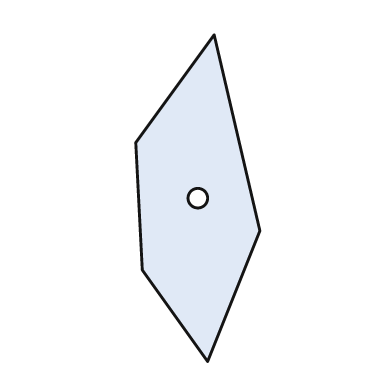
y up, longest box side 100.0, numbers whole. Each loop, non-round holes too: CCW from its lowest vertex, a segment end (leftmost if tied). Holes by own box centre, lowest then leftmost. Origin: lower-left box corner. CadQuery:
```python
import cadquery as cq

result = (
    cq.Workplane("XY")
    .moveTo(22.0, 0.0)
    .lineTo(38.0, 40.0)
    .lineTo(24.0, 100.0)
    .lineTo(0.0, 67.0)
    .lineTo(2.0, 28.0)
    .close()
    .moveTo(19.0, 50.0)
    .circle(3.0)
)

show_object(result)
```